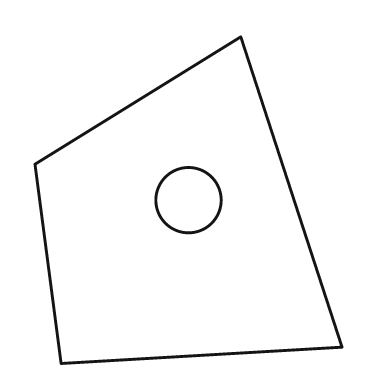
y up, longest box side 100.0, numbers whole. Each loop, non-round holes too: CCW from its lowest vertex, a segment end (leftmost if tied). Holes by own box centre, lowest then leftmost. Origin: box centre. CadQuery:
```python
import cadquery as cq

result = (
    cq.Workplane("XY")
    .moveTo(-39.0, -50.0)
    .lineTo(47.0, -45.0)
    .lineTo(16.0, 50.0)
    .lineTo(-47.0, 11.0)
    .close()
    .moveTo(0.0, 0.0)
    .circle(10.0)
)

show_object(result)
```